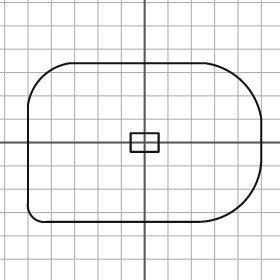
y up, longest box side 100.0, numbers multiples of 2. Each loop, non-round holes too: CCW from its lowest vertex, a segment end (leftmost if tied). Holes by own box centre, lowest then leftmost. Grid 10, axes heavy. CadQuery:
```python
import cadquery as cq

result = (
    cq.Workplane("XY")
    .moveTo(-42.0, -34.0)
    .lineTo(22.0, -34.0)
    .threePointArc((42.0, -26.0), (50.0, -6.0))
    .lineTo(50.0, 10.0)
    .threePointArc((42.0, 26.0), (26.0, 34.0))
    .lineTo(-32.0, 34.0)
    .threePointArc((-44.0, 28.0), (-50.0, 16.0))
    .lineTo(-50.0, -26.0)
    .threePointArc((-48.0, -32.0), (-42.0, -34.0))
    .close()
    .moveTo(-6.0, -4.0)
    .lineTo(6.0, -4.0)
    .lineTo(6.0, 4.0)
    .lineTo(-6.0, 4.0)
    .close()
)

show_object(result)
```